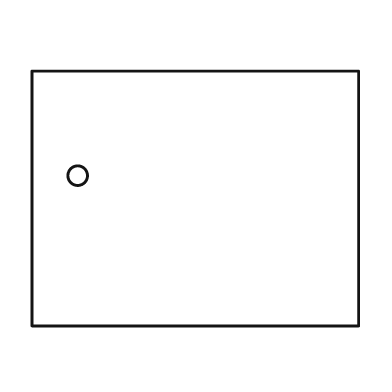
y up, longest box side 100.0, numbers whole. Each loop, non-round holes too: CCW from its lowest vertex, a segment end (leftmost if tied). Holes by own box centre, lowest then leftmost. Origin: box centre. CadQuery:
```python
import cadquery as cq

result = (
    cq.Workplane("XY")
    .moveTo(-50.0, -39.0)
    .lineTo(50.0, -39.0)
    .lineTo(50.0, 39.0)
    .lineTo(-50.0, 39.0)
    .close()
    .moveTo(-36.0, 7.0)
    .circle(3.0)
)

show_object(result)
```